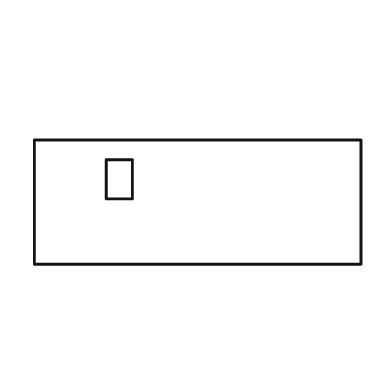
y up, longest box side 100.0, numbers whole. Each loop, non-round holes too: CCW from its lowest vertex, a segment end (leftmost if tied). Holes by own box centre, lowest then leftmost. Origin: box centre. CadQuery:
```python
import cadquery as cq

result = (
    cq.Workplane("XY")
    .moveTo(-50.0, -19.0)
    .lineTo(50.0, -19.0)
    .lineTo(50.0, 19.0)
    .lineTo(-50.0, 19.0)
    .close()
    .moveTo(-28.0, 1.0)
    .lineTo(-20.0, 1.0)
    .lineTo(-20.0, 13.0)
    .lineTo(-28.0, 13.0)
    .close()
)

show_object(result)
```